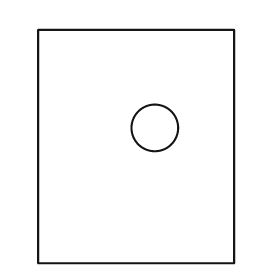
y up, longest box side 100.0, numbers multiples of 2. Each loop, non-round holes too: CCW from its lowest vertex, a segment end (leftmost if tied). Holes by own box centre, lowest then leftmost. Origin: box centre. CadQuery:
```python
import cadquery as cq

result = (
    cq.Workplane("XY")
    .moveTo(-42.0, -50.0)
    .lineTo(42.0, -50.0)
    .lineTo(42.0, 50.0)
    .lineTo(-42.0, 50.0)
    .close()
    .moveTo(8.0, 8.0)
    .circle(10.0)
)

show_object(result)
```